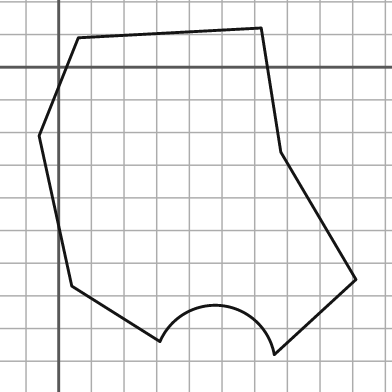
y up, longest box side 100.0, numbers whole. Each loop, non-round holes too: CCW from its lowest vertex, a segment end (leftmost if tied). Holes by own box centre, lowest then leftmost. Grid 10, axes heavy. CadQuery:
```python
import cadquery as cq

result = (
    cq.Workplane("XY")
    .moveTo(66.0, -88.0)
    .lineTo(91.0, -65.0)
    .lineTo(68.0, -26.0)
    .lineTo(62.0, 12.0)
    .lineTo(6.0, 9.0)
    .lineTo(-6.0, -21.0)
    .lineTo(4.0, -67.0)
    .lineTo(31.0, -84.0)
    .threePointArc((50.0, -73.0), (66.0, -88.0))
    .close()
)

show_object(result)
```